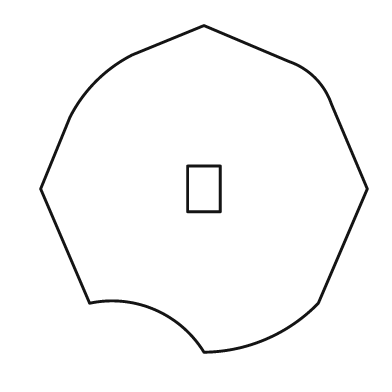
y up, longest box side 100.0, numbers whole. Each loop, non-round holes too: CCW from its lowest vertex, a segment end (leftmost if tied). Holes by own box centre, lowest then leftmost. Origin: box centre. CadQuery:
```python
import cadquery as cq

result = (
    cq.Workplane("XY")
    .moveTo(0.0, -50.0)
    .threePointArc((19.0, -46.0), (35.0, -35.0))
    .lineTo(50.0, 0.0)
    .lineTo(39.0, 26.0)
    .threePointArc((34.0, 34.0), (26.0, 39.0))
    .lineTo(0.0, 50.0)
    .lineTo(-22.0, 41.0)
    .threePointArc((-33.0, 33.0), (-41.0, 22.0))
    .lineTo(-50.0, 0.0)
    .lineTo(-35.0, -35.0)
    .threePointArc((-15.0, -37.0), (0.0, -50.0))
    .close()
    .moveTo(-5.0, -7.0)
    .lineTo(5.0, -7.0)
    .lineTo(5.0, 7.0)
    .lineTo(-5.0, 7.0)
    .close()
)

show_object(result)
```